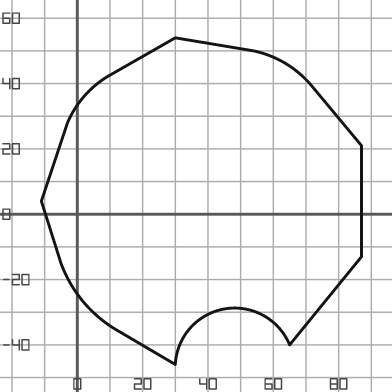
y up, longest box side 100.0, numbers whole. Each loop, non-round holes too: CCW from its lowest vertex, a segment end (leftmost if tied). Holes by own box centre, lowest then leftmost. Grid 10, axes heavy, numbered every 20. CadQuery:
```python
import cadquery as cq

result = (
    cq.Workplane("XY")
    .moveTo(30.0, -46.0)
    .threePointArc((45.0, -29.0), (65.0, -40.0))
    .lineTo(87.0, -13.0)
    .lineTo(87.0, 21.0)
    .lineTo(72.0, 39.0)
    .threePointArc((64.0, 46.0), (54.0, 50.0))
    .lineTo(30.0, 54.0)
    .lineTo(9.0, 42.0)
    .threePointArc((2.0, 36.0), (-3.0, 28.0))
    .lineTo(-11.0, 4.0)
    .lineTo(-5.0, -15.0)
    .threePointArc((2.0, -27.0), (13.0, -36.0))
    .close()
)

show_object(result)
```